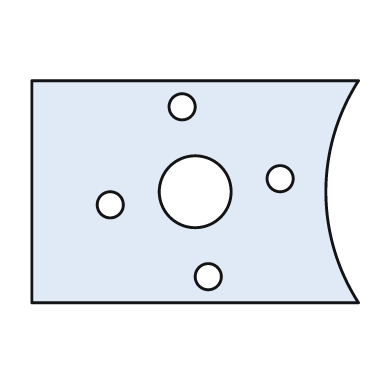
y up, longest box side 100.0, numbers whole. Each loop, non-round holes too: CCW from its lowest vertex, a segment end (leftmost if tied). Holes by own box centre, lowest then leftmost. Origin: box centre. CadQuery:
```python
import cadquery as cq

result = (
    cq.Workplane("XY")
    .moveTo(-50.0, -34.0)
    .lineTo(50.0, -34.0)
    .threePointArc((40.0, 0.0), (50.0, 34.0))
    .lineTo(-50.0, 34.0)
    .close()
    .moveTo(4.0, -26.0)
    .circle(4.0)
    .moveTo(-26.0, -4.0)
    .circle(4.0)
    .moveTo(0.0, 0.0)
    .circle(11.0)
    .moveTo(26.0, 4.0)
    .circle(4.0)
    .moveTo(-4.0, 26.0)
    .circle(4.0)
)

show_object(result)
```